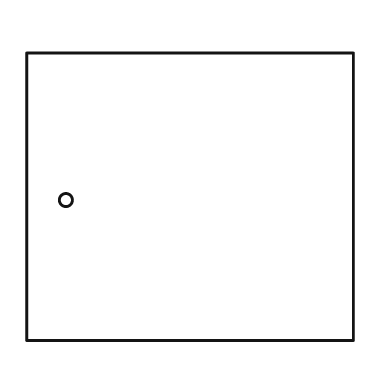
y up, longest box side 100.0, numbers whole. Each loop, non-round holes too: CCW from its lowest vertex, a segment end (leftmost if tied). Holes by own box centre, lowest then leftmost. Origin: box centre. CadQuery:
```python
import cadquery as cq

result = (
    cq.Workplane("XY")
    .moveTo(-50.0, -44.0)
    .lineTo(50.0, -44.0)
    .lineTo(50.0, 44.0)
    .lineTo(-50.0, 44.0)
    .close()
    .moveTo(-38.0, -1.0)
    .circle(2.0)
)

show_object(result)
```